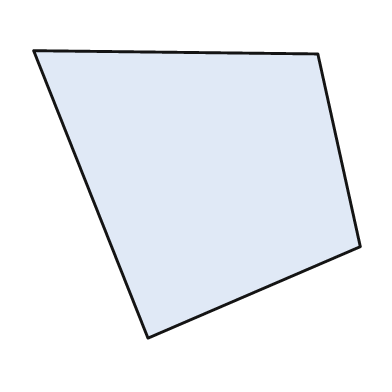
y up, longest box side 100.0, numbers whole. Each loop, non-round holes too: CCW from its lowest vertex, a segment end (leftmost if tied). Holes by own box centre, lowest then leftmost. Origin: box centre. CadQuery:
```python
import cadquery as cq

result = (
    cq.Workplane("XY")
    .moveTo(-15.0, -44.0)
    .lineTo(50.0, -16.0)
    .lineTo(37.0, 43.0)
    .lineTo(-50.0, 44.0)
    .close()
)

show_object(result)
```